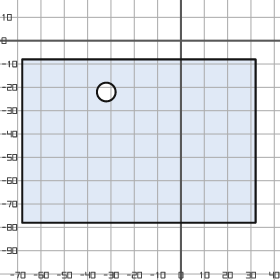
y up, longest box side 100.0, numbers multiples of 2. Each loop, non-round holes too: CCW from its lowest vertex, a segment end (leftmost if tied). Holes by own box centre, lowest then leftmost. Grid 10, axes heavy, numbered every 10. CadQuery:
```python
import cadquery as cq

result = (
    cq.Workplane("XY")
    .moveTo(-68.0, -78.0)
    .lineTo(32.0, -78.0)
    .lineTo(32.0, -8.0)
    .lineTo(-68.0, -8.0)
    .close()
    .moveTo(-32.0, -22.0)
    .circle(4.0)
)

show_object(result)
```